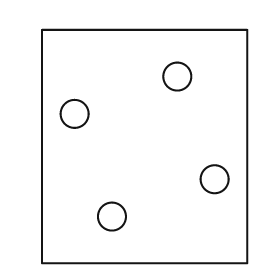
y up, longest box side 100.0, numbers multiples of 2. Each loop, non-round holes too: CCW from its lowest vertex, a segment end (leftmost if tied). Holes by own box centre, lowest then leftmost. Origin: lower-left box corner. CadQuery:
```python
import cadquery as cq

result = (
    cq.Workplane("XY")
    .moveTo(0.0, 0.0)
    .lineTo(88.0, 0.0)
    .lineTo(88.0, 100.0)
    .lineTo(0.0, 100.0)
    .close()
    .moveTo(30.0, 20.0)
    .circle(6.0)
    .moveTo(74.0, 36.0)
    .circle(6.0)
    .moveTo(14.0, 64.0)
    .circle(6.0)
    .moveTo(58.0, 80.0)
    .circle(6.0)
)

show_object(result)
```